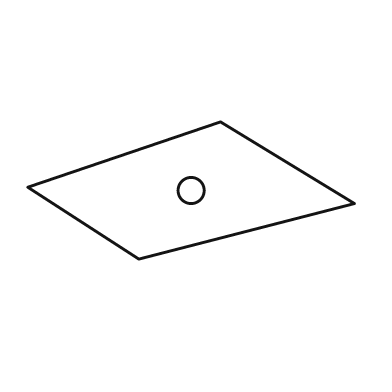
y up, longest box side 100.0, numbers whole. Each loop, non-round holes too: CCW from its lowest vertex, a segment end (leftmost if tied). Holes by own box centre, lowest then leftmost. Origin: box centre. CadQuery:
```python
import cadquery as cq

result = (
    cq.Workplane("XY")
    .moveTo(-16.0, -21.0)
    .lineTo(50.0, -4.0)
    .lineTo(9.0, 21.0)
    .lineTo(-50.0, 1.0)
    .close()
    .moveTo(0.0, 0.0)
    .circle(4.0)
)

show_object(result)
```